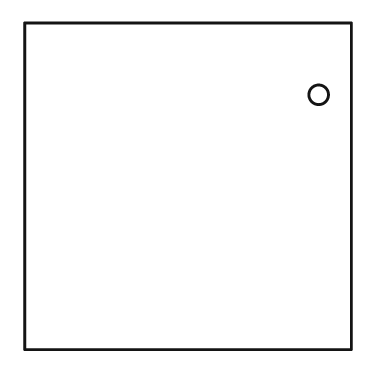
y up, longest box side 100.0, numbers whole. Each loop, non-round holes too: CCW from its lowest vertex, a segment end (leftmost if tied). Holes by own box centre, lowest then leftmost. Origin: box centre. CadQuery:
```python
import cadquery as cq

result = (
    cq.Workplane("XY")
    .moveTo(-50.0, -50.0)
    .lineTo(50.0, -50.0)
    .lineTo(50.0, 50.0)
    .lineTo(-50.0, 50.0)
    .close()
    .moveTo(40.0, 28.0)
    .circle(3.0)
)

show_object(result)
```